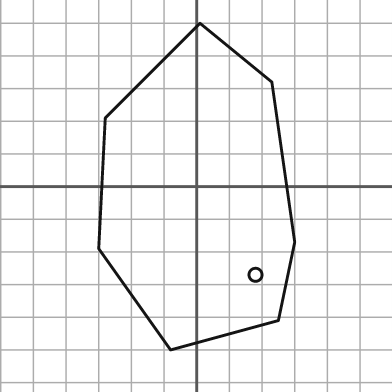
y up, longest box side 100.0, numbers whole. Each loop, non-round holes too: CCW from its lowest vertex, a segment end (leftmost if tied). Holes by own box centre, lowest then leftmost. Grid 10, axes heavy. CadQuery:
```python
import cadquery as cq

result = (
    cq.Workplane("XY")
    .moveTo(-8.0, -50.0)
    .lineTo(25.0, -41.0)
    .lineTo(30.0, -17.0)
    .lineTo(23.0, 32.0)
    .lineTo(1.0, 50.0)
    .lineTo(-28.0, 21.0)
    .lineTo(-30.0, -19.0)
    .close()
    .moveTo(18.0, -27.0)
    .circle(2.0)
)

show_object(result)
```